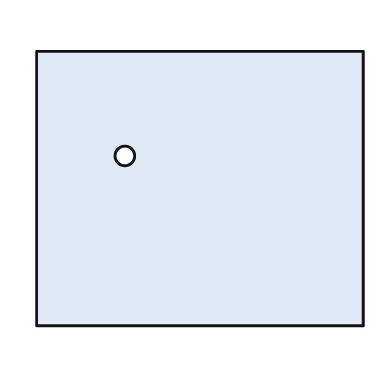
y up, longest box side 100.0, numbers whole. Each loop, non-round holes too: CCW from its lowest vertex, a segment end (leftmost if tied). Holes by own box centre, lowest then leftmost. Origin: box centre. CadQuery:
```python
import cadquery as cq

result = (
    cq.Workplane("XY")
    .moveTo(-50.0, -42.0)
    .lineTo(50.0, -42.0)
    .lineTo(50.0, 42.0)
    .lineTo(-50.0, 42.0)
    .close()
    .moveTo(-23.0, 10.0)
    .circle(3.0)
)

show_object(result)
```